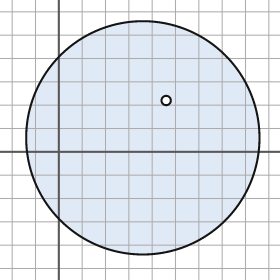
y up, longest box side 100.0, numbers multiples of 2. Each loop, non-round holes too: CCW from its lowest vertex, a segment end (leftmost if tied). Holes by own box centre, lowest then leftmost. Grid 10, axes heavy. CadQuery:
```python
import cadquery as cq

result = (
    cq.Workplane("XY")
    .moveTo(36.0, 6.0)
    .circle(50.0)
    .moveTo(46.0, 22.0)
    .circle(2.0)
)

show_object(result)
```